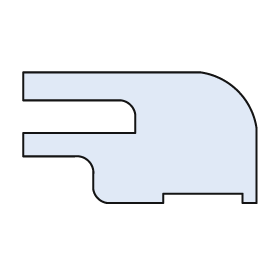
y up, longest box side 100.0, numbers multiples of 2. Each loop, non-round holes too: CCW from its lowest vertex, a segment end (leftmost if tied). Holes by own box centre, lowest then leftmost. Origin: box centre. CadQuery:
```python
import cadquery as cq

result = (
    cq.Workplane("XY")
    .moveTo(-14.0, -28.0)
    .lineTo(10.0, -28.0)
    .lineTo(10.0, -24.0)
    .lineTo(44.0, -24.0)
    .lineTo(44.0, -28.0)
    .lineTo(50.0, -28.0)
    .lineTo(50.0, 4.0)
    .threePointArc((42.0, 20.0), (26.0, 28.0))
    .lineTo(-50.0, 28.0)
    .lineTo(-50.0, 16.0)
    .lineTo(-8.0, 16.0)
    .threePointArc((-4.0, 14.0), (-2.0, 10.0))
    .lineTo(-2.0, 2.0)
    .lineTo(-50.0, 2.0)
    .lineTo(-50.0, -8.0)
    .lineTo(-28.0, -8.0)
    .threePointArc((-22.0, -10.0), (-20.0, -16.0))
    .lineTo(-20.0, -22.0)
    .threePointArc((-18.0, -26.0), (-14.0, -28.0))
    .close()
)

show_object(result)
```